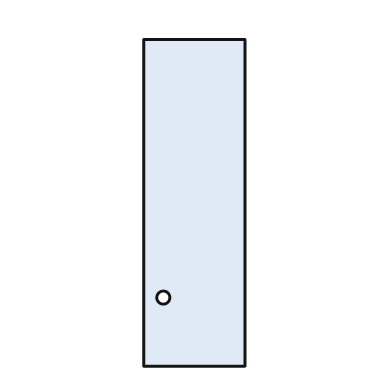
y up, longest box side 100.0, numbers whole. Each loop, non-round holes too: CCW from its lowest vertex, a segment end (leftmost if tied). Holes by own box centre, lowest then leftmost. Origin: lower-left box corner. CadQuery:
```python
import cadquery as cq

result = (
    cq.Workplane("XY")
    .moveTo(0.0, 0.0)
    .lineTo(31.0, 0.0)
    .lineTo(31.0, 100.0)
    .lineTo(0.0, 100.0)
    .close()
    .moveTo(6.0, 21.0)
    .circle(2.0)
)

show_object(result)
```